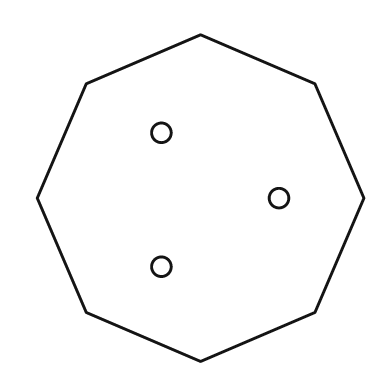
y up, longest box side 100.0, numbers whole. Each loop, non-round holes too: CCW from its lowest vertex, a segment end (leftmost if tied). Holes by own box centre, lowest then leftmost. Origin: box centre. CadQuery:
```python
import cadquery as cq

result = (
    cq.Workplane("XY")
    .moveTo(0.0, -50.0)
    .lineTo(35.0, -35.0)
    .lineTo(50.0, 0.0)
    .lineTo(35.0, 35.0)
    .lineTo(0.0, 50.0)
    .lineTo(-35.0, 35.0)
    .lineTo(-50.0, 0.0)
    .lineTo(-35.0, -35.0)
    .close()
    .moveTo(-12.0, -21.0)
    .circle(3.0)
    .moveTo(24.0, 0.0)
    .circle(3.0)
    .moveTo(-12.0, 20.0)
    .circle(3.0)
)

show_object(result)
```